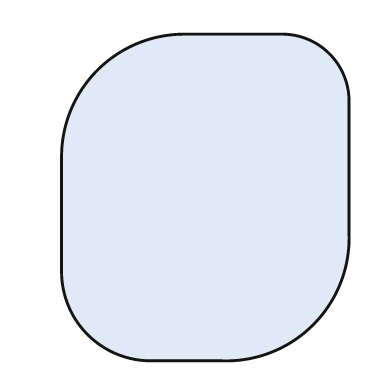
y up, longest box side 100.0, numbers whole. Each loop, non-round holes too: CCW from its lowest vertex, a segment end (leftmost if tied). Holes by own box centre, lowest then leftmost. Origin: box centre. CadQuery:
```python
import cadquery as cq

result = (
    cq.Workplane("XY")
    .moveTo(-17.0, -50.0)
    .lineTo(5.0, -50.0)
    .threePointArc((33.0, -39.0), (44.0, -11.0))
    .lineTo(44.0, 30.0)
    .threePointArc((38.0, 44.0), (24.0, 50.0))
    .lineTo(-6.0, 50.0)
    .threePointArc((-33.0, 39.0), (-44.0, 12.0))
    .lineTo(-44.0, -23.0)
    .threePointArc((-36.0, -42.0), (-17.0, -50.0))
    .close()
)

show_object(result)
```